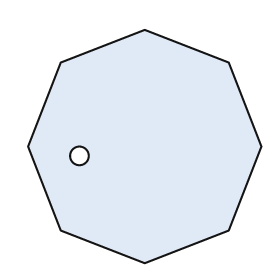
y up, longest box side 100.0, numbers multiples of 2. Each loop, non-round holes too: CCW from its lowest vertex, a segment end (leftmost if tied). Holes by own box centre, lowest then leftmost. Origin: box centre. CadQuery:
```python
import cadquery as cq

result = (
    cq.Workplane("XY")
    .moveTo(0.0, -50.0)
    .lineTo(36.0, -36.0)
    .lineTo(50.0, 0.0)
    .lineTo(36.0, 36.0)
    .lineTo(0.0, 50.0)
    .lineTo(-36.0, 36.0)
    .lineTo(-50.0, 0.0)
    .lineTo(-36.0, -36.0)
    .close()
    .moveTo(-28.0, -4.0)
    .circle(4.0)
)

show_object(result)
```